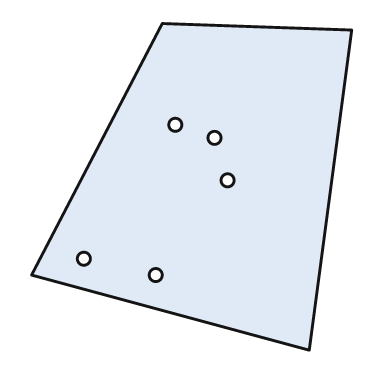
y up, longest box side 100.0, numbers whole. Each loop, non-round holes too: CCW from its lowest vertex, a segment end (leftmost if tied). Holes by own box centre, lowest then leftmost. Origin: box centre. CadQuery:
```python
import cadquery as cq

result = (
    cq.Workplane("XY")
    .moveTo(36.0, -50.0)
    .lineTo(49.0, 48.0)
    .lineTo(-9.0, 50.0)
    .lineTo(-49.0, -27.0)
    .close()
    .moveTo(-11.0, -27.0)
    .circle(2.0)
    .moveTo(-33.0, -22.0)
    .circle(2.0)
    .moveTo(11.0, 2.0)
    .circle(2.0)
    .moveTo(7.0, 15.0)
    .circle(2.0)
    .moveTo(-5.0, 19.0)
    .circle(2.0)
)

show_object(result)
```